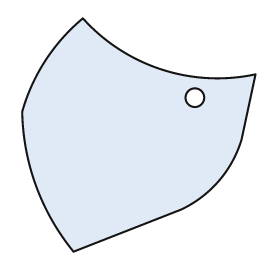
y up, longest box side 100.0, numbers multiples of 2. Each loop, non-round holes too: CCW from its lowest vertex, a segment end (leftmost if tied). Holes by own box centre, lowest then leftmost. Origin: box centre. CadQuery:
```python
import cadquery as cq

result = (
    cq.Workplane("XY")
    .moveTo(-28.0, -50.0)
    .lineTo(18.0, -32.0)
    .threePointArc((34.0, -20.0), (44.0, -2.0))
    .lineTo(50.0, 26.0)
    .threePointArc((10.0, 28.0), (-24.0, 50.0))
    .threePointArc((-40.0, 32.0), (-50.0, 10.0))
    .threePointArc((-44.0, -22.0), (-28.0, -50.0))
    .close()
    .moveTo(24.0, 16.0)
    .circle(4.0)
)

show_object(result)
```